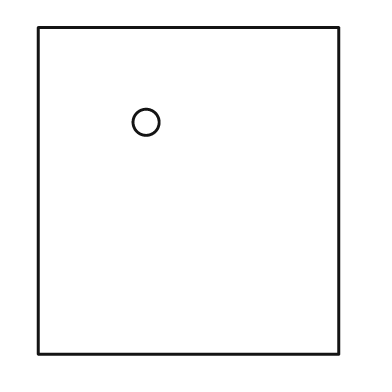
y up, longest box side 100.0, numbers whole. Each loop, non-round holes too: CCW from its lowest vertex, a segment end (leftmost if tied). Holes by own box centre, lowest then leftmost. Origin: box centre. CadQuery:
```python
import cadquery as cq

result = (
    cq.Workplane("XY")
    .moveTo(-46.0, -50.0)
    .lineTo(46.0, -50.0)
    .lineTo(46.0, 50.0)
    .lineTo(-46.0, 50.0)
    .close()
    .moveTo(-13.0, 21.0)
    .circle(4.0)
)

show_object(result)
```